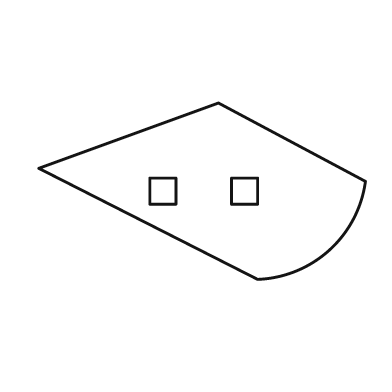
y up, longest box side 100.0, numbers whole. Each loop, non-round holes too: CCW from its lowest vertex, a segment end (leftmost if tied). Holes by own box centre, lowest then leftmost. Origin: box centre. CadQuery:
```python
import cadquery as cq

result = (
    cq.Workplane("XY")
    .moveTo(17.0, -27.0)
    .threePointArc((39.0, -18.0), (50.0, 3.0))
    .lineTo(5.0, 27.0)
    .lineTo(-50.0, 7.0)
    .close()
    .moveTo(-16.0, -4.0)
    .lineTo(-8.0, -4.0)
    .lineTo(-8.0, 4.0)
    .lineTo(-16.0, 4.0)
    .close()
    .moveTo(9.0, -4.0)
    .lineTo(17.0, -4.0)
    .lineTo(17.0, 4.0)
    .lineTo(9.0, 4.0)
    .close()
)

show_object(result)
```